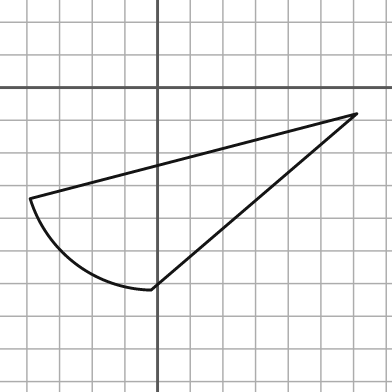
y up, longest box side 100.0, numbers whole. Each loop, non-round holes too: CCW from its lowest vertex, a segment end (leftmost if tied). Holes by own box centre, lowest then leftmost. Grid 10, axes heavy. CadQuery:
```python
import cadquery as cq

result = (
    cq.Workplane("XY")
    .moveTo(-2.0, -62.0)
    .lineTo(61.0, -8.0)
    .lineTo(-39.0, -34.0)
    .threePointArc((-25.0, -54.0), (-2.0, -62.0))
    .close()
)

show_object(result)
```